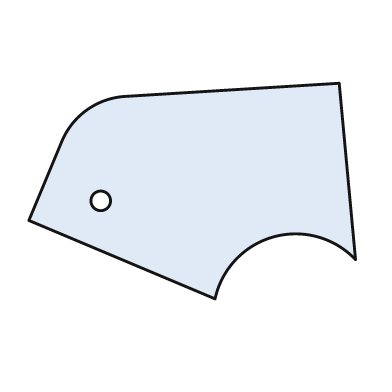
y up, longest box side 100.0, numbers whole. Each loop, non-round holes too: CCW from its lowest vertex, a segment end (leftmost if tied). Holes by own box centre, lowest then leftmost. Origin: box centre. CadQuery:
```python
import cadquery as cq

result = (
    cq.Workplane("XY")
    .moveTo(7.0, -33.0)
    .threePointArc((25.0, -14.0), (50.0, -21.0))
    .lineTo(45.0, 33.0)
    .lineTo(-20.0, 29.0)
    .threePointArc((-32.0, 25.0), (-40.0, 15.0))
    .lineTo(-50.0, -9.0)
    .close()
    .moveTo(-28.0, -3.0)
    .circle(3.0)
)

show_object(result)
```